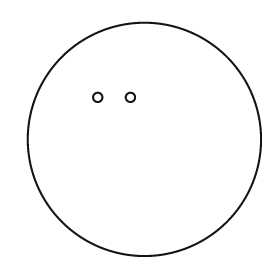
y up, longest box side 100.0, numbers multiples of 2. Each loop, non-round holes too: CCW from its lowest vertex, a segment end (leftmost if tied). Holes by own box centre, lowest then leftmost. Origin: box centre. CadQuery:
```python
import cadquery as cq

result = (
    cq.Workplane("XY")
    .moveTo(0.0, 0.0)
    .circle(50.0)
    .moveTo(-20.0, 18.0)
    .circle(2.0)
    .moveTo(-6.0, 18.0)
    .circle(2.0)
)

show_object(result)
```